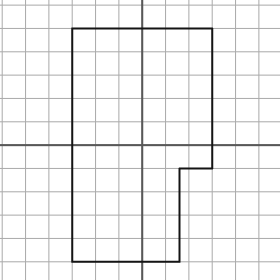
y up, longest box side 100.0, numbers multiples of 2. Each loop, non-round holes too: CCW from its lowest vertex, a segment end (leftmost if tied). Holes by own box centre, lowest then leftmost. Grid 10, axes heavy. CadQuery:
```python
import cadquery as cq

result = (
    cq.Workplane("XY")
    .moveTo(-30.0, -50.0)
    .lineTo(16.0, -50.0)
    .lineTo(16.0, -10.0)
    .lineTo(30.0, -10.0)
    .lineTo(30.0, 50.0)
    .lineTo(-30.0, 50.0)
    .close()
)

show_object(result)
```